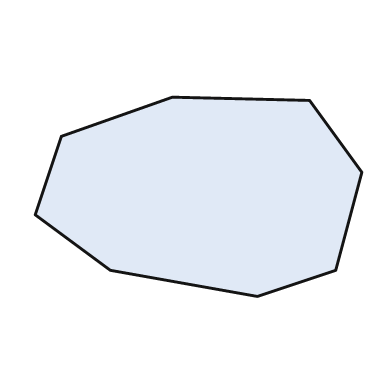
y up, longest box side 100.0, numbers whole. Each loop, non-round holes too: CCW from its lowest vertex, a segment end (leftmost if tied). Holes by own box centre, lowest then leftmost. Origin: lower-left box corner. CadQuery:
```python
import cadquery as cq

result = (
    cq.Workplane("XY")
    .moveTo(68.0, 0.0)
    .lineTo(92.0, 8.0)
    .lineTo(100.0, 38.0)
    .lineTo(84.0, 60.0)
    .lineTo(42.0, 61.0)
    .lineTo(8.0, 49.0)
    .lineTo(0.0, 25.0)
    .lineTo(23.0, 8.0)
    .close()
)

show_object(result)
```